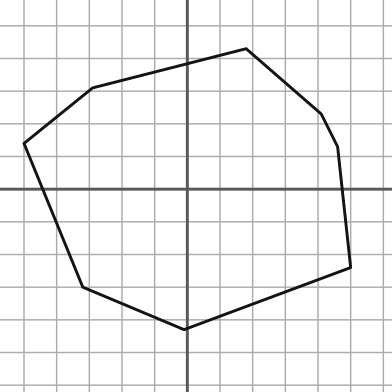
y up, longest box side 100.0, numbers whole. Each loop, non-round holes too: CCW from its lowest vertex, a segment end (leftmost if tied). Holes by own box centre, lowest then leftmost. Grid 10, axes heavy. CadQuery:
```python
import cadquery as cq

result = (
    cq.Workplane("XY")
    .moveTo(-1.0, -43.0)
    .lineTo(50.0, -24.0)
    .lineTo(46.0, 13.0)
    .lineTo(41.0, 23.0)
    .lineTo(18.0, 43.0)
    .lineTo(-29.0, 31.0)
    .lineTo(-50.0, 14.0)
    .lineTo(-32.0, -30.0)
    .close()
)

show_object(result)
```